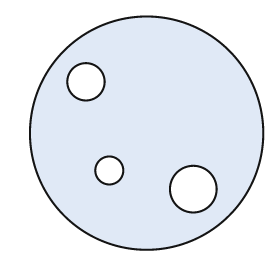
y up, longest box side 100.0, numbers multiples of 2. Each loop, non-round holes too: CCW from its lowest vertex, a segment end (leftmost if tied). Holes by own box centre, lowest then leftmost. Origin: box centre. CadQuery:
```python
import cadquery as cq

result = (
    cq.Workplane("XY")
    .moveTo(0.0, 0.0)
    .circle(50.0)
    .moveTo(20.0, -24.0)
    .circle(10.0)
    .moveTo(-16.0, -16.0)
    .circle(6.0)
    .moveTo(-26.0, 22.0)
    .circle(8.0)
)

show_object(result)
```